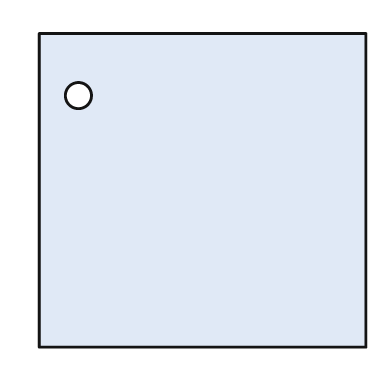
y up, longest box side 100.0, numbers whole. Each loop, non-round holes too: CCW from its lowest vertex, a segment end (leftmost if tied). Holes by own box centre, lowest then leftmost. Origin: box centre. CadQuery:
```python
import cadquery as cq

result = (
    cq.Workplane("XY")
    .moveTo(-50.0, -48.0)
    .lineTo(50.0, -48.0)
    .lineTo(50.0, 48.0)
    .lineTo(-50.0, 48.0)
    .close()
    .moveTo(-38.0, 29.0)
    .circle(4.0)
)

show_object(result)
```